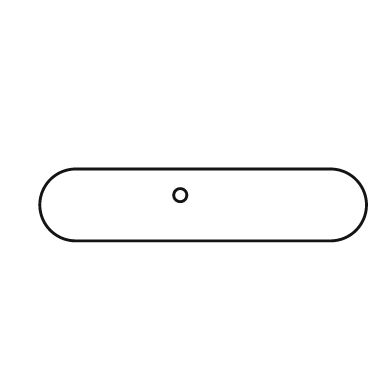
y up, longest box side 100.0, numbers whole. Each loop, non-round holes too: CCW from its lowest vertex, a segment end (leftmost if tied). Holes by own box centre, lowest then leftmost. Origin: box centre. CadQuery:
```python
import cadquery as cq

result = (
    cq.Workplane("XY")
    .moveTo(-39.0, -11.0)
    .lineTo(39.0, -11.0)
    .threePointArc((50.0, 0.0), (39.0, 11.0))
    .lineTo(-39.0, 11.0)
    .threePointArc((-50.0, 0.0), (-39.0, -11.0))
    .close()
    .moveTo(-7.0, 3.0)
    .circle(2.0)
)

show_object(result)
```